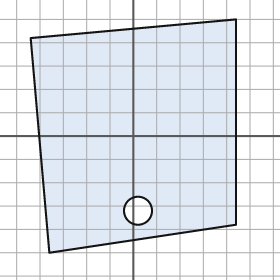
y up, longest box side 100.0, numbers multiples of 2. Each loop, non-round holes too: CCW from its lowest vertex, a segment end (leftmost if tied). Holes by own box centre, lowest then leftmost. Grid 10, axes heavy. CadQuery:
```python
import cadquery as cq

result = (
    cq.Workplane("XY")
    .moveTo(-36.0, -50.0)
    .lineTo(44.0, -38.0)
    .lineTo(44.0, 50.0)
    .lineTo(-44.0, 42.0)
    .close()
    .moveTo(2.0, -32.0)
    .circle(6.0)
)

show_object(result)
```